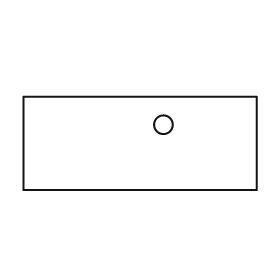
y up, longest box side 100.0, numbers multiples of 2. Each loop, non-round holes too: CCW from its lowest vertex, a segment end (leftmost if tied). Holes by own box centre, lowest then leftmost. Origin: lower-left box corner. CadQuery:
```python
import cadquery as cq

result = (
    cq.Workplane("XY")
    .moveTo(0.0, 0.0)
    .lineTo(100.0, 0.0)
    .lineTo(100.0, 40.0)
    .lineTo(0.0, 40.0)
    .close()
    .moveTo(60.0, 28.0)
    .circle(4.0)
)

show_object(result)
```